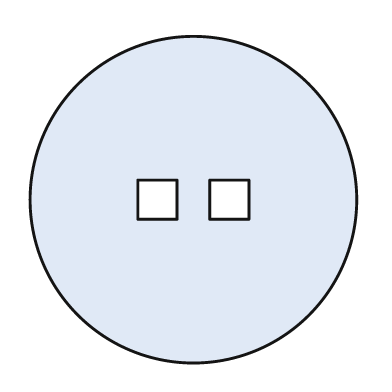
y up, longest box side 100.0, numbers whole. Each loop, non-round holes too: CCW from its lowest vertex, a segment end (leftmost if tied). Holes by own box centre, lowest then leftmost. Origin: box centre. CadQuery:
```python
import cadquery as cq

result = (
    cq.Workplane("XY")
    .moveTo(0.0, 0.0)
    .circle(50.0)
    .moveTo(-17.0, -6.0)
    .lineTo(-5.0, -6.0)
    .lineTo(-5.0, 6.0)
    .lineTo(-17.0, 6.0)
    .close()
    .moveTo(5.0, -6.0)
    .lineTo(17.0, -6.0)
    .lineTo(17.0, 6.0)
    .lineTo(5.0, 6.0)
    .close()
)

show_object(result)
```